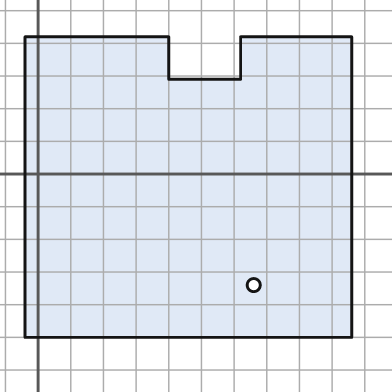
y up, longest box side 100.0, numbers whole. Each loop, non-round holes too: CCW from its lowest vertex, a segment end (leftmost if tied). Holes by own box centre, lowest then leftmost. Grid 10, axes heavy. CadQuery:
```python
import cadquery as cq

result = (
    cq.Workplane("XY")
    .moveTo(-4.0, -50.0)
    .lineTo(96.0, -50.0)
    .lineTo(96.0, 42.0)
    .lineTo(62.0, 42.0)
    .lineTo(62.0, 29.0)
    .lineTo(40.0, 29.0)
    .lineTo(40.0, 42.0)
    .lineTo(-4.0, 42.0)
    .close()
    .moveTo(66.0, -34.0)
    .circle(2.0)
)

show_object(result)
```